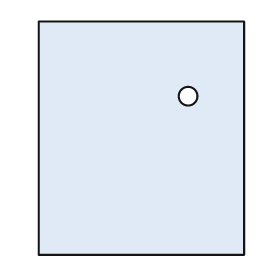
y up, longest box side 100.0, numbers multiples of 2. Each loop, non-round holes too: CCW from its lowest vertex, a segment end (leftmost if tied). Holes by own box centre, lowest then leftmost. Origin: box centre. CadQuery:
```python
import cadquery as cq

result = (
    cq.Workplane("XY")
    .moveTo(-44.0, -50.0)
    .lineTo(44.0, -50.0)
    .lineTo(44.0, 50.0)
    .lineTo(-44.0, 50.0)
    .close()
    .moveTo(20.0, 18.0)
    .circle(4.0)
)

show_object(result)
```